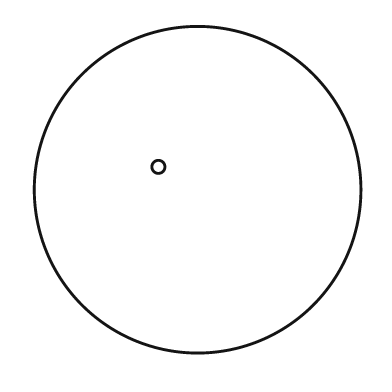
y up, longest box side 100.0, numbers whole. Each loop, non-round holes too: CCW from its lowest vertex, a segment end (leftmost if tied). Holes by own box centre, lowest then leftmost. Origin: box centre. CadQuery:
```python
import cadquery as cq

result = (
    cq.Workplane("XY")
    .moveTo(0.0, 0.0)
    .circle(50.0)
    .moveTo(-12.0, 7.0)
    .circle(2.0)
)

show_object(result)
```